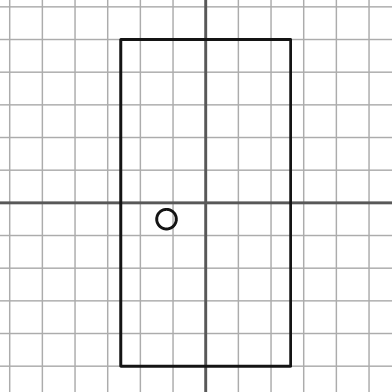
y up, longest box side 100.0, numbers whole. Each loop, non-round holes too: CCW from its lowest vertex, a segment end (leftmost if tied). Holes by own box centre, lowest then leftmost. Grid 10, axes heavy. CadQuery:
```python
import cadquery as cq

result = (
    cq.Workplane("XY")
    .moveTo(-26.0, -50.0)
    .lineTo(26.0, -50.0)
    .lineTo(26.0, 50.0)
    .lineTo(-26.0, 50.0)
    .close()
    .moveTo(-12.0, -5.0)
    .circle(3.0)
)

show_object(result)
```